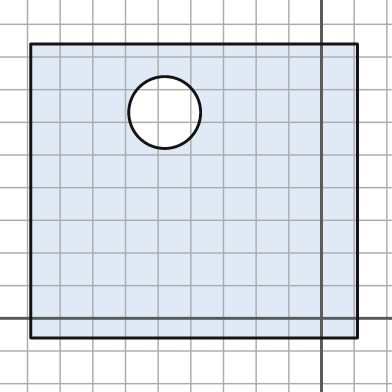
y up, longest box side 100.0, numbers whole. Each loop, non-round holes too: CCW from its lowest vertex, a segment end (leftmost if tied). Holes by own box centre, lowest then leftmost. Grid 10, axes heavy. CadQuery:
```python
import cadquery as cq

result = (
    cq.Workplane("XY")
    .moveTo(-89.0, -6.0)
    .lineTo(11.0, -6.0)
    .lineTo(11.0, 84.0)
    .lineTo(-89.0, 84.0)
    .close()
    .moveTo(-48.0, 63.0)
    .circle(11.0)
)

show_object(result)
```